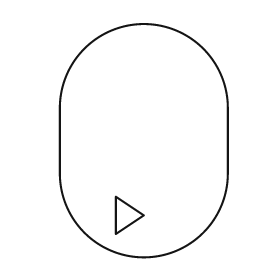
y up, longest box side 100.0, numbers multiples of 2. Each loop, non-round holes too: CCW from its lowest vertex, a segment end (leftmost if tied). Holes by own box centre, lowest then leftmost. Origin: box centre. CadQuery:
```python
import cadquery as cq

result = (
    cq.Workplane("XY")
    .moveTo(-36.0, -14.0)
    .threePointArc((0.0, -50.0), (36.0, -14.0))
    .lineTo(36.0, 14.0)
    .threePointArc((0.0, 50.0), (-36.0, 14.0))
    .close()
    .moveTo(-12.0, -40.0)
    .lineTo(0.0, -32.0)
    .lineTo(-12.0, -24.0)
    .close()
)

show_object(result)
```